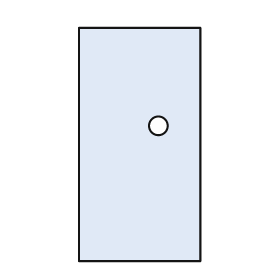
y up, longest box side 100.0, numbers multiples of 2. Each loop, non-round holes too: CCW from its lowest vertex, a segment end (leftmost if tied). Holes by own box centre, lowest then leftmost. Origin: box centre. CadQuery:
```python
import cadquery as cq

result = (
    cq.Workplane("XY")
    .moveTo(-26.0, -50.0)
    .lineTo(26.0, -50.0)
    .lineTo(26.0, 50.0)
    .lineTo(-26.0, 50.0)
    .close()
    .moveTo(8.0, 8.0)
    .circle(4.0)
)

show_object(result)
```